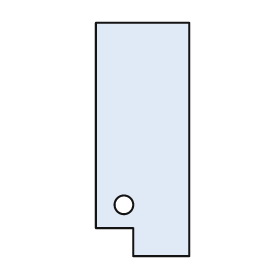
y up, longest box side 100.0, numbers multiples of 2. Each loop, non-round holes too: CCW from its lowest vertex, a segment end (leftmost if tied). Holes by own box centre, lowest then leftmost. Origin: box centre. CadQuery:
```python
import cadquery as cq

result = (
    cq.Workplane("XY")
    .moveTo(-4.0, -50.0)
    .lineTo(20.0, -50.0)
    .lineTo(20.0, 50.0)
    .lineTo(-20.0, 50.0)
    .lineTo(-20.0, -38.0)
    .lineTo(-4.0, -38.0)
    .close()
    .moveTo(-8.0, -28.0)
    .circle(4.0)
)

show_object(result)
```